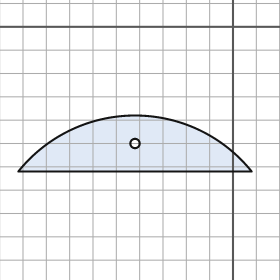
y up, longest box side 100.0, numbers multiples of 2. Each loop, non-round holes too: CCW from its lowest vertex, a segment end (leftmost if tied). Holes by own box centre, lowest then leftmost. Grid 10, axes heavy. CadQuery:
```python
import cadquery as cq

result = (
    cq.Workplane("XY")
    .moveTo(-92.0, -62.0)
    .lineTo(8.0, -62.0)
    .threePointArc((-42.0, -38.0), (-92.0, -62.0))
    .close()
    .moveTo(-42.0, -50.0)
    .circle(2.0)
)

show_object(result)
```